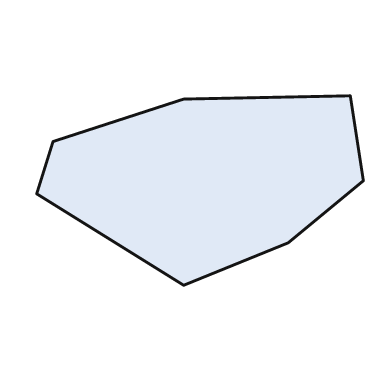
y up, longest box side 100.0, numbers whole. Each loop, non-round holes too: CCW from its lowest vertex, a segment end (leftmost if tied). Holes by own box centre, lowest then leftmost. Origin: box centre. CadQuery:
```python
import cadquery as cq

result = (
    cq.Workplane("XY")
    .moveTo(-5.0, -29.0)
    .lineTo(27.0, -16.0)
    .lineTo(50.0, 3.0)
    .lineTo(46.0, 29.0)
    .lineTo(-5.0, 28.0)
    .lineTo(-45.0, 15.0)
    .lineTo(-50.0, -1.0)
    .close()
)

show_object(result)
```